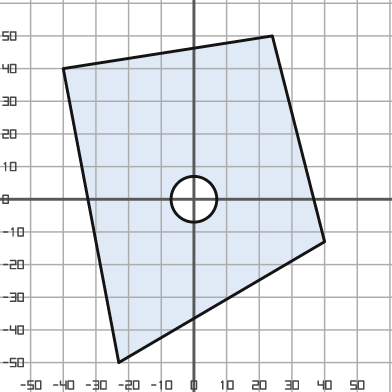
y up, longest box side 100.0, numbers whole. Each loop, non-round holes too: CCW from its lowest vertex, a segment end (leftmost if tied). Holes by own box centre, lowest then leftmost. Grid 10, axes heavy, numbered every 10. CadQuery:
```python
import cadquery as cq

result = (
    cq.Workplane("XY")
    .moveTo(-23.0, -50.0)
    .lineTo(40.0, -13.0)
    .lineTo(24.0, 50.0)
    .lineTo(-40.0, 40.0)
    .close()
    .moveTo(0.0, 0.0)
    .circle(7.0)
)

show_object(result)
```